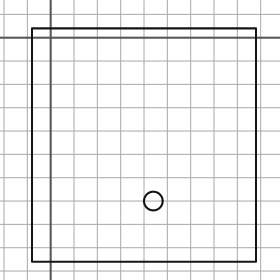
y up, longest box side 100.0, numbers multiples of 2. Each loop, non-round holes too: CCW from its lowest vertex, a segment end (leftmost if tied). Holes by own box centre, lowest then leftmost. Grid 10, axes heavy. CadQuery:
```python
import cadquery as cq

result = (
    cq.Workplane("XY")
    .moveTo(-8.0, -96.0)
    .lineTo(88.0, -96.0)
    .lineTo(88.0, 4.0)
    .lineTo(-8.0, 4.0)
    .close()
    .moveTo(44.0, -70.0)
    .circle(4.0)
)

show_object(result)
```